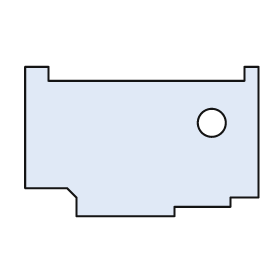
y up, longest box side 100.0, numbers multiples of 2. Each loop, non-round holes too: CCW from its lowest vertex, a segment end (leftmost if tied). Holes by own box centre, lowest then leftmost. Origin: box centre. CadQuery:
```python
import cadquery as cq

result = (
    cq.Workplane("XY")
    .moveTo(-28.0, -32.0)
    .lineTo(14.0, -32.0)
    .lineTo(14.0, -28.0)
    .lineTo(38.0, -28.0)
    .lineTo(38.0, -24.0)
    .lineTo(50.0, -24.0)
    .lineTo(50.0, 32.0)
    .lineTo(44.0, 32.0)
    .lineTo(44.0, 26.0)
    .lineTo(-40.0, 26.0)
    .lineTo(-40.0, 32.0)
    .lineTo(-50.0, 32.0)
    .lineTo(-50.0, -20.0)
    .lineTo(-32.0, -20.0)
    .lineTo(-28.0, -24.0)
    .close()
    .moveTo(30.0, 8.0)
    .circle(6.0)
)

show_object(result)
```